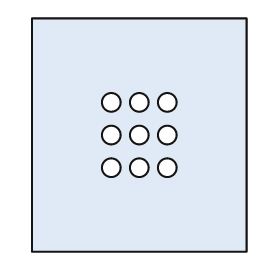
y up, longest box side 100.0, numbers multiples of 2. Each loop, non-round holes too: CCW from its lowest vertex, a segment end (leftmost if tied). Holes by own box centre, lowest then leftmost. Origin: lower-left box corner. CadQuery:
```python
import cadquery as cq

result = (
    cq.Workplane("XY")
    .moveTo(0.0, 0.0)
    .lineTo(92.0, 0.0)
    .lineTo(92.0, 100.0)
    .lineTo(0.0, 100.0)
    .close()
    .moveTo(34.0, 36.0)
    .circle(4.0)
    .moveTo(46.0, 36.0)
    .circle(4.0)
    .moveTo(58.0, 36.0)
    .circle(4.0)
    .moveTo(34.0, 50.0)
    .circle(4.0)
    .moveTo(46.0, 50.0)
    .circle(4.0)
    .moveTo(58.0, 50.0)
    .circle(4.0)
    .moveTo(34.0, 64.0)
    .circle(4.0)
    .moveTo(46.0, 64.0)
    .circle(4.0)
    .moveTo(58.0, 64.0)
    .circle(4.0)
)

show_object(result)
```